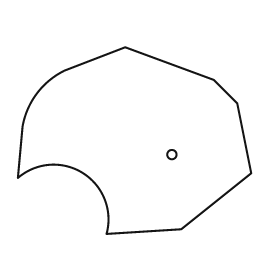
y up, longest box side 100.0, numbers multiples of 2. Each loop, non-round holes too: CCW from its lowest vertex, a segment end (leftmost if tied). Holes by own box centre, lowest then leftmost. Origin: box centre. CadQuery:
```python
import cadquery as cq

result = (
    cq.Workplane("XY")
    .moveTo(-12.0, -40.0)
    .lineTo(20.0, -38.0)
    .lineTo(50.0, -14.0)
    .lineTo(44.0, 16.0)
    .lineTo(34.0, 26.0)
    .lineTo(-4.0, 40.0)
    .lineTo(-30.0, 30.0)
    .threePointArc((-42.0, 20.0), (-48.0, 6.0))
    .lineTo(-50.0, -16.0)
    .threePointArc((-22.0, -14.0), (-12.0, -40.0))
    .close()
    .moveTo(16.0, -6.0)
    .circle(2.0)
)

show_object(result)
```